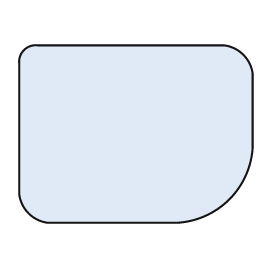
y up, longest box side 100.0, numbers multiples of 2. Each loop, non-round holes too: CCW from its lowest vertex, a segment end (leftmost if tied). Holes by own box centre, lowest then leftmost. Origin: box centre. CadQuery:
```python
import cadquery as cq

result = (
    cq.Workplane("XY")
    .moveTo(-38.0, -38.0)
    .lineTo(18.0, -38.0)
    .threePointArc((40.0, -28.0), (50.0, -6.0))
    .lineTo(50.0, 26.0)
    .threePointArc((46.0, 34.0), (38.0, 38.0))
    .lineTo(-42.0, 38.0)
    .threePointArc((-48.0, 36.0), (-50.0, 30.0))
    .lineTo(-50.0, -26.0)
    .threePointArc((-46.0, -34.0), (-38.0, -38.0))
    .close()
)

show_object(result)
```